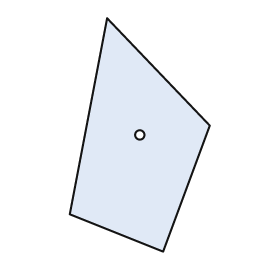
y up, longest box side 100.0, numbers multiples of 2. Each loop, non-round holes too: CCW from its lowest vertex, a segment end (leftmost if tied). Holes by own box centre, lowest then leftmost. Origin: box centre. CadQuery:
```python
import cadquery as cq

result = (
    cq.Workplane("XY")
    .moveTo(10.0, -50.0)
    .lineTo(30.0, 4.0)
    .lineTo(-14.0, 50.0)
    .lineTo(-30.0, -34.0)
    .close()
    .moveTo(0.0, 0.0)
    .circle(2.0)
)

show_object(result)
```